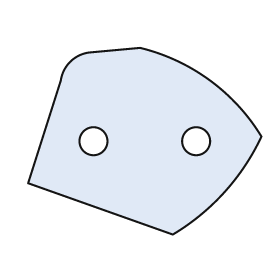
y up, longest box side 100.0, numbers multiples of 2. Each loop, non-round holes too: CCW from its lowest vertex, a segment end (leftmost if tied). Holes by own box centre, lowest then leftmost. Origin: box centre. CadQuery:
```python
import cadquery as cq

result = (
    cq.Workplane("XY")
    .moveTo(12.0, -40.0)
    .threePointArc((34.0, -22.0), (50.0, 2.0))
    .threePointArc((28.0, 26.0), (-2.0, 40.0))
    .lineTo(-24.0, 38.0)
    .threePointArc((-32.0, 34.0), (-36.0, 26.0))
    .lineTo(-50.0, -18.0)
    .close()
    .moveTo(-22.0, 0.0)
    .circle(6.0)
    .moveTo(22.0, 0.0)
    .circle(6.0)
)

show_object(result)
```